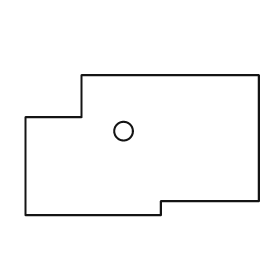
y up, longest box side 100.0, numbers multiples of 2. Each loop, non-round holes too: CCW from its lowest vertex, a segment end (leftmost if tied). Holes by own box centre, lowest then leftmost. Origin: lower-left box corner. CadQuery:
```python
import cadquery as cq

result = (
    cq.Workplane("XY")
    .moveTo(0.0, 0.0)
    .lineTo(58.0, 0.0)
    .lineTo(58.0, 6.0)
    .lineTo(100.0, 6.0)
    .lineTo(100.0, 60.0)
    .lineTo(24.0, 60.0)
    .lineTo(24.0, 42.0)
    .lineTo(0.0, 42.0)
    .close()
    .moveTo(42.0, 36.0)
    .circle(4.0)
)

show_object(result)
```